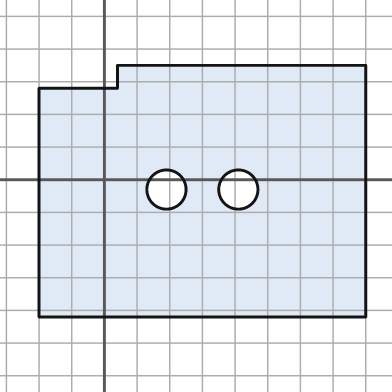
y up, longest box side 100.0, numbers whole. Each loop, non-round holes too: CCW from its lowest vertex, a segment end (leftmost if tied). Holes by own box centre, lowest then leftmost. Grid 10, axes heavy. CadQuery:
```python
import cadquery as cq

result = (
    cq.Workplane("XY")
    .moveTo(-20.0, -42.0)
    .lineTo(80.0, -42.0)
    .lineTo(80.0, 35.0)
    .lineTo(4.0, 35.0)
    .lineTo(4.0, 28.0)
    .lineTo(-20.0, 28.0)
    .close()
    .moveTo(19.0, -3.0)
    .circle(6.0)
    .moveTo(41.0, -3.0)
    .circle(6.0)
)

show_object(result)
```